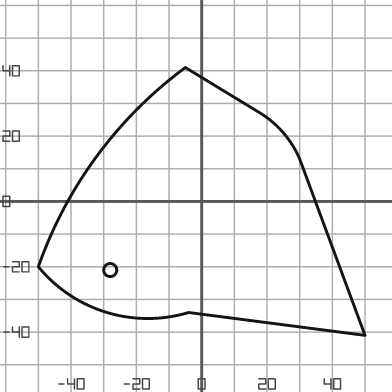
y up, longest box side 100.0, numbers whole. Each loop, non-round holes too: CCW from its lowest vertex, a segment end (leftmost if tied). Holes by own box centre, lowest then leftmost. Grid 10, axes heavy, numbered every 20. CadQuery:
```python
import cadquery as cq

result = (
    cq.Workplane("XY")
    .moveTo(50.0, -41.0)
    .lineTo(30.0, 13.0)
    .threePointArc((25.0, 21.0), (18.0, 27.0))
    .lineTo(-5.0, 41.0)
    .threePointArc((-32.0, 14.0), (-50.0, -20.0))
    .threePointArc((-29.0, -34.0), (-4.0, -34.0))
    .close()
    .moveTo(-28.0, -21.0)
    .circle(2.0)
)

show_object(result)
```